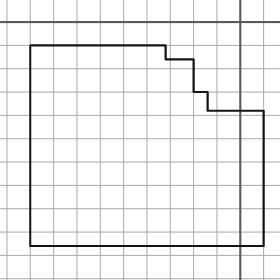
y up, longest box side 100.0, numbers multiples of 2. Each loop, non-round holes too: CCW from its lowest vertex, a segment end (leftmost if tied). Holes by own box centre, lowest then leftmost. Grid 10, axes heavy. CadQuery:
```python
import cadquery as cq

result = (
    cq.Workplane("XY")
    .moveTo(-90.0, -96.0)
    .lineTo(10.0, -96.0)
    .lineTo(10.0, -38.0)
    .lineTo(-14.0, -38.0)
    .lineTo(-14.0, -30.0)
    .lineTo(-20.0, -30.0)
    .lineTo(-20.0, -16.0)
    .lineTo(-32.0, -16.0)
    .lineTo(-32.0, -10.0)
    .lineTo(-90.0, -10.0)
    .close()
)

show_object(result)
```